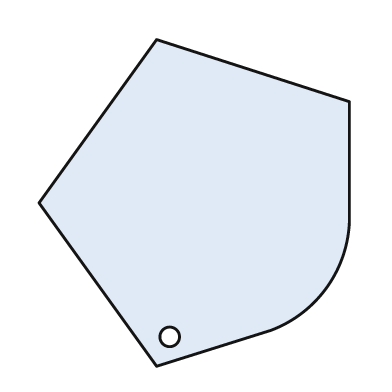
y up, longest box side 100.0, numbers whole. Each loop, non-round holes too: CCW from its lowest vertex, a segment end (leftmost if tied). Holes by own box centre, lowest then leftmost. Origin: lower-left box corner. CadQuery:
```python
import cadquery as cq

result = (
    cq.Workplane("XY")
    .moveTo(36.0, 0.0)
    .lineTo(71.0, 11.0)
    .threePointArc((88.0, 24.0), (95.0, 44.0))
    .lineTo(95.0, 81.0)
    .lineTo(36.0, 100.0)
    .lineTo(0.0, 50.0)
    .close()
    .moveTo(40.0, 9.0)
    .circle(3.0)
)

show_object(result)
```